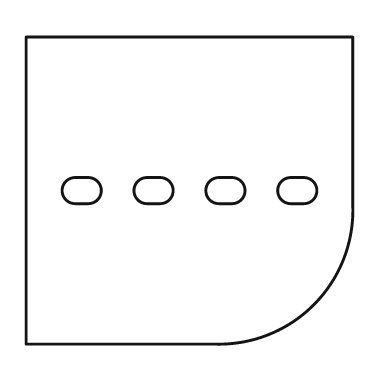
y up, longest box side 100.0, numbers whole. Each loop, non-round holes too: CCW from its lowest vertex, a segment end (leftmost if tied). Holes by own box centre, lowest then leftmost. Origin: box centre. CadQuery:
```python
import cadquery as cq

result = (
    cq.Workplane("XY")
    .moveTo(-50.0, -47.0)
    .lineTo(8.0, -47.0)
    .threePointArc((38.0, -35.0), (50.0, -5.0))
    .lineTo(50.0, 47.0)
    .lineTo(-50.0, 47.0)
    .close()
    .moveTo(-35.0, -4.0)
    .lineTo(-31.0, -4.0)
    .threePointArc((-27.0, 0.0), (-31.0, 4.0))
    .lineTo(-35.0, 4.0)
    .threePointArc((-39.0, 0.0), (-35.0, -4.0))
    .close()
    .moveTo(-13.0, -4.0)
    .lineTo(-9.0, -4.0)
    .threePointArc((-5.0, 0.0), (-9.0, 4.0))
    .lineTo(-13.0, 4.0)
    .threePointArc((-17.0, 0.0), (-13.0, -4.0))
    .close()
    .moveTo(9.0, -4.0)
    .lineTo(13.0, -4.0)
    .threePointArc((17.0, 0.0), (13.0, 4.0))
    .lineTo(9.0, 4.0)
    .threePointArc((5.0, 0.0), (9.0, -4.0))
    .close()
    .moveTo(31.0, -4.0)
    .lineTo(35.0, -4.0)
    .threePointArc((39.0, 0.0), (35.0, 4.0))
    .lineTo(31.0, 4.0)
    .threePointArc((27.0, 0.0), (31.0, -4.0))
    .close()
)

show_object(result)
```